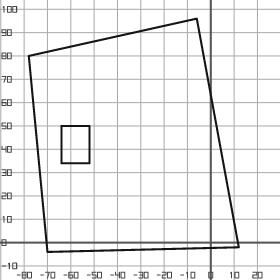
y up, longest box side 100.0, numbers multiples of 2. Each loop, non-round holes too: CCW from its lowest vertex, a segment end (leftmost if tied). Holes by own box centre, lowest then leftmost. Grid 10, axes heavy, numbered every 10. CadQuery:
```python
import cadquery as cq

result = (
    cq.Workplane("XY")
    .moveTo(-70.0, -4.0)
    .lineTo(12.0, -2.0)
    .lineTo(-6.0, 96.0)
    .lineTo(-78.0, 80.0)
    .close()
    .moveTo(-64.0, 34.0)
    .lineTo(-52.0, 34.0)
    .lineTo(-52.0, 50.0)
    .lineTo(-64.0, 50.0)
    .close()
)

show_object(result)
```